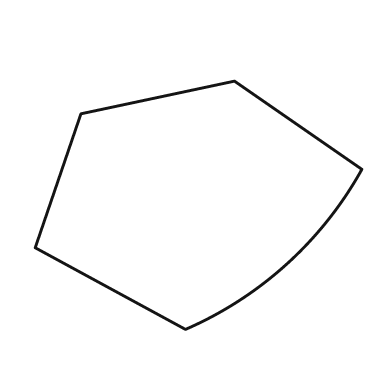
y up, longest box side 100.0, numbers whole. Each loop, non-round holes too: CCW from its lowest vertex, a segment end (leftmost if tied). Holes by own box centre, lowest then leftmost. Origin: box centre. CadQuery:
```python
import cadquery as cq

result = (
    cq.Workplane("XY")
    .moveTo(-4.0, -38.0)
    .threePointArc((27.0, -18.0), (50.0, 11.0))
    .lineTo(11.0, 38.0)
    .lineTo(-36.0, 28.0)
    .lineTo(-50.0, -13.0)
    .close()
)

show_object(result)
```